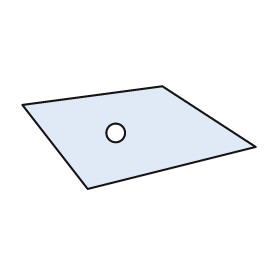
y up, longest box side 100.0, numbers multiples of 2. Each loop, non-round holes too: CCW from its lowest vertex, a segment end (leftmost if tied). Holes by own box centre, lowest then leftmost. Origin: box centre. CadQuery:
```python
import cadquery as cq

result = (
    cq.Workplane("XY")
    .moveTo(-22.0, -22.0)
    .lineTo(50.0, -4.0)
    .lineTo(10.0, 22.0)
    .lineTo(-50.0, 14.0)
    .close()
    .moveTo(-10.0, 2.0)
    .circle(4.0)
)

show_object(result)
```